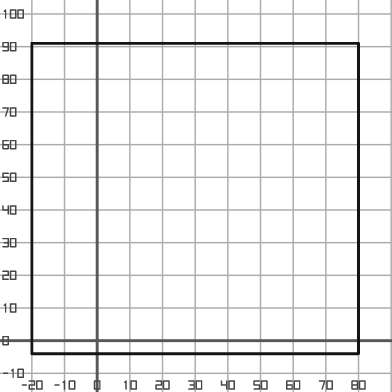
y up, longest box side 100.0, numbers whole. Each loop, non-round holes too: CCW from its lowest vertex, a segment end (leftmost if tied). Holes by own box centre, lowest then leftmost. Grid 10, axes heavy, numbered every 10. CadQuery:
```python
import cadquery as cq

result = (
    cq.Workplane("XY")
    .moveTo(-20.0, -4.0)
    .lineTo(80.0, -4.0)
    .lineTo(80.0, 91.0)
    .lineTo(-20.0, 91.0)
    .close()
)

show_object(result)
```